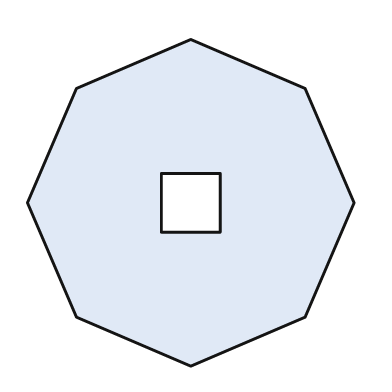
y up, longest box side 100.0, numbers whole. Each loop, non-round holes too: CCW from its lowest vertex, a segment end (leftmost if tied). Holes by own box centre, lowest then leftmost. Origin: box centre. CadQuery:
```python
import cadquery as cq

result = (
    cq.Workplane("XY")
    .moveTo(0.0, -50.0)
    .lineTo(35.0, -35.0)
    .lineTo(50.0, 0.0)
    .lineTo(35.0, 35.0)
    .lineTo(0.0, 50.0)
    .lineTo(-35.0, 35.0)
    .lineTo(-50.0, 0.0)
    .lineTo(-35.0, -35.0)
    .close()
    .moveTo(-9.0, -9.0)
    .lineTo(9.0, -9.0)
    .lineTo(9.0, 9.0)
    .lineTo(-9.0, 9.0)
    .close()
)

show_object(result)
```